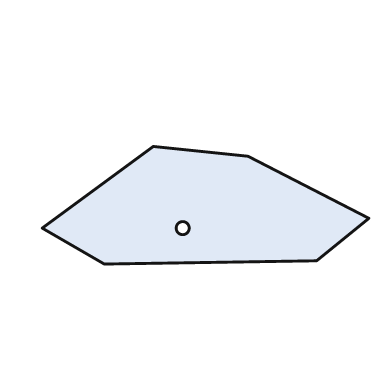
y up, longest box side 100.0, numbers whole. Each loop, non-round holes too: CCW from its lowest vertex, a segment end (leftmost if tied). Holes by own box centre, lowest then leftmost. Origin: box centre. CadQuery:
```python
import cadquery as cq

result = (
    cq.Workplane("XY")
    .moveTo(-31.0, -18.0)
    .lineTo(34.0, -17.0)
    .lineTo(50.0, -4.0)
    .lineTo(13.0, 15.0)
    .lineTo(-16.0, 18.0)
    .lineTo(-50.0, -7.0)
    .close()
    .moveTo(-7.0, -7.0)
    .circle(2.0)
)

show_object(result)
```